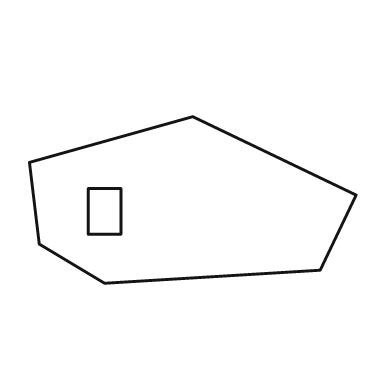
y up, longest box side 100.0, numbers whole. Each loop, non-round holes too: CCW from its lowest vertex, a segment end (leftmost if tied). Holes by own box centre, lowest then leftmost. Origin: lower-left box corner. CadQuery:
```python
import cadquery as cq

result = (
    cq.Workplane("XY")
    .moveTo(23.0, 0.0)
    .lineTo(89.0, 4.0)
    .lineTo(100.0, 27.0)
    .lineTo(50.0, 51.0)
    .lineTo(0.0, 37.0)
    .lineTo(3.0, 12.0)
    .close()
    .moveTo(18.0, 15.0)
    .lineTo(28.0, 15.0)
    .lineTo(28.0, 29.0)
    .lineTo(18.0, 29.0)
    .close()
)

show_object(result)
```